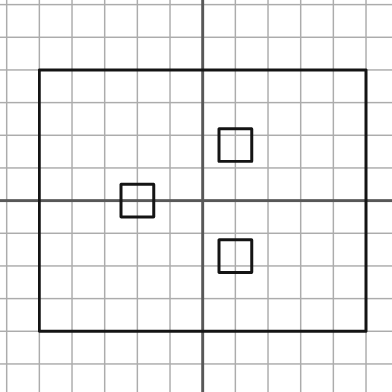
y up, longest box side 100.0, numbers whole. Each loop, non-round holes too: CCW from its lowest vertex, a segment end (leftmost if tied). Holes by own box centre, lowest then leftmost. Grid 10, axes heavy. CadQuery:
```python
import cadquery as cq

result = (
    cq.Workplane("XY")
    .moveTo(-50.0, -40.0)
    .lineTo(50.0, -40.0)
    .lineTo(50.0, 40.0)
    .lineTo(-50.0, 40.0)
    .close()
    .moveTo(5.0, -22.0)
    .lineTo(15.0, -22.0)
    .lineTo(15.0, -12.0)
    .lineTo(5.0, -12.0)
    .close()
    .moveTo(-25.0, -5.0)
    .lineTo(-15.0, -5.0)
    .lineTo(-15.0, 5.0)
    .lineTo(-25.0, 5.0)
    .close()
    .moveTo(5.0, 12.0)
    .lineTo(15.0, 12.0)
    .lineTo(15.0, 22.0)
    .lineTo(5.0, 22.0)
    .close()
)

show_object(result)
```